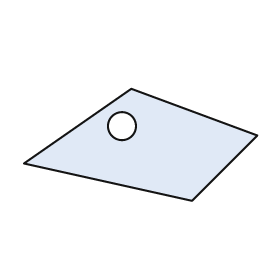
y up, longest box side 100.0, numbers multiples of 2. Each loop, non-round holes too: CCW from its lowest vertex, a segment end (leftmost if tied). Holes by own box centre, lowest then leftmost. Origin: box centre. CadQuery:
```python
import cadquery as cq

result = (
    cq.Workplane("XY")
    .moveTo(22.0, -24.0)
    .lineTo(50.0, 4.0)
    .lineTo(-4.0, 24.0)
    .lineTo(-50.0, -8.0)
    .close()
    .moveTo(-8.0, 8.0)
    .circle(6.0)
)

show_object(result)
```